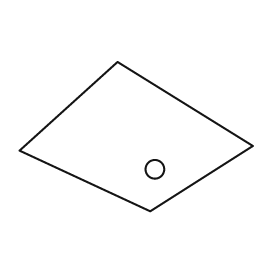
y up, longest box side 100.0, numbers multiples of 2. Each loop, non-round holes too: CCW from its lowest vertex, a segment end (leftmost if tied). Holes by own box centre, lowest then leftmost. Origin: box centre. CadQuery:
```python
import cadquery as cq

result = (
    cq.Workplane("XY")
    .moveTo(6.0, -32.0)
    .lineTo(50.0, -4.0)
    .lineTo(-8.0, 32.0)
    .lineTo(-50.0, -6.0)
    .close()
    .moveTo(8.0, -14.0)
    .circle(4.0)
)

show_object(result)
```